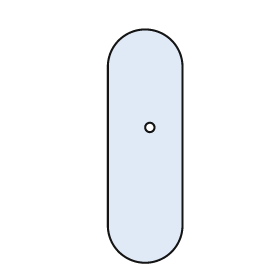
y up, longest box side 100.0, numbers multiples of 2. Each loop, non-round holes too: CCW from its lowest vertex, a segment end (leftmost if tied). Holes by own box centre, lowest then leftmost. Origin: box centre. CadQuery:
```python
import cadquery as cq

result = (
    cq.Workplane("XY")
    .moveTo(-16.0, -34.0)
    .threePointArc((0.0, -50.0), (16.0, -34.0))
    .lineTo(16.0, 34.0)
    .threePointArc((0.0, 50.0), (-16.0, 34.0))
    .close()
    .moveTo(2.0, 8.0)
    .circle(2.0)
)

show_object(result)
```